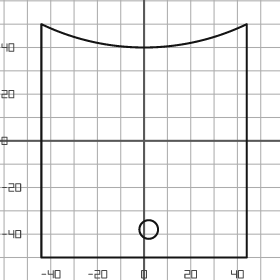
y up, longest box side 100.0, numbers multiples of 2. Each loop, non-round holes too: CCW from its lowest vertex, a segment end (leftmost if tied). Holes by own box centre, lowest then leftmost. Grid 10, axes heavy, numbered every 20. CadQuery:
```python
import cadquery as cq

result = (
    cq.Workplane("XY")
    .moveTo(-44.0, -50.0)
    .lineTo(44.0, -50.0)
    .lineTo(44.0, 50.0)
    .threePointArc((0.0, 40.0), (-44.0, 50.0))
    .close()
    .moveTo(2.0, -38.0)
    .circle(4.0)
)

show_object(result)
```